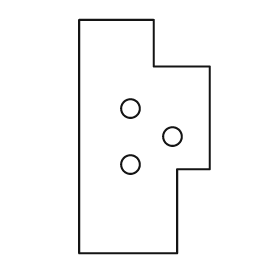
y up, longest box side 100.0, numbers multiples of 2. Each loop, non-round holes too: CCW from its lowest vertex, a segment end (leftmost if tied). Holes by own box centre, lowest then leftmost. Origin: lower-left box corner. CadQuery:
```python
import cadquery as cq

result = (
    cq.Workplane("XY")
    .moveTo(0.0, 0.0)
    .lineTo(42.0, 0.0)
    .lineTo(42.0, 36.0)
    .lineTo(56.0, 36.0)
    .lineTo(56.0, 80.0)
    .lineTo(32.0, 80.0)
    .lineTo(32.0, 100.0)
    .lineTo(0.0, 100.0)
    .close()
    .moveTo(22.0, 38.0)
    .circle(4.0)
    .moveTo(40.0, 50.0)
    .circle(4.0)
    .moveTo(22.0, 62.0)
    .circle(4.0)
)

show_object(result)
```